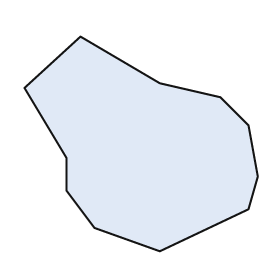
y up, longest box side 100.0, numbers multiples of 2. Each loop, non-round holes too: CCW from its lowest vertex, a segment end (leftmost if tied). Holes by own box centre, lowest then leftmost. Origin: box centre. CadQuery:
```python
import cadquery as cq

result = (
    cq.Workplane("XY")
    .moveTo(8.0, -46.0)
    .lineTo(46.0, -28.0)
    .lineTo(50.0, -14.0)
    .lineTo(46.0, 8.0)
    .lineTo(34.0, 20.0)
    .lineTo(8.0, 26.0)
    .lineTo(-26.0, 46.0)
    .lineTo(-50.0, 24.0)
    .lineTo(-32.0, -6.0)
    .lineTo(-32.0, -20.0)
    .lineTo(-20.0, -36.0)
    .close()
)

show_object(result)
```